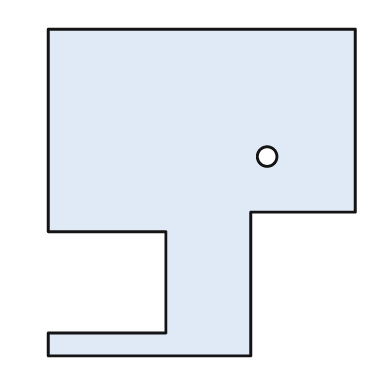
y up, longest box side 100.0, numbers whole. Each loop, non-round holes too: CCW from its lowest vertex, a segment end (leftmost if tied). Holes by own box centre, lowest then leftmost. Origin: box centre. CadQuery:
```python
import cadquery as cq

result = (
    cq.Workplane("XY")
    .moveTo(-47.0, -50.0)
    .lineTo(15.0, -50.0)
    .lineTo(15.0, -6.0)
    .lineTo(47.0, -6.0)
    .lineTo(47.0, 50.0)
    .lineTo(-47.0, 50.0)
    .lineTo(-47.0, -12.0)
    .lineTo(-11.0, -12.0)
    .lineTo(-11.0, -43.0)
    .lineTo(-47.0, -43.0)
    .close()
    .moveTo(20.0, 11.0)
    .circle(3.0)
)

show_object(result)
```